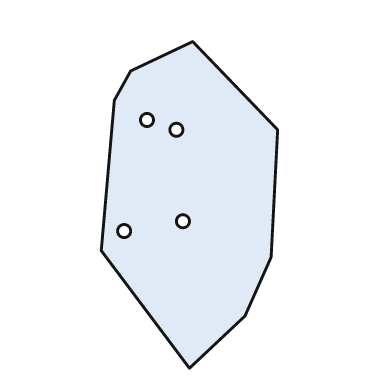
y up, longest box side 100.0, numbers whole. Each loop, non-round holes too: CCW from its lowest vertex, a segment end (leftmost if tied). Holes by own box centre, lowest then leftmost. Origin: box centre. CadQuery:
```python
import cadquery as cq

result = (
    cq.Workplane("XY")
    .moveTo(0.0, -50.0)
    .lineTo(17.0, -34.0)
    .lineTo(25.0, -16.0)
    .lineTo(27.0, 23.0)
    .lineTo(1.0, 50.0)
    .lineTo(-18.0, 41.0)
    .lineTo(-23.0, 32.0)
    .lineTo(-27.0, -14.0)
    .close()
    .moveTo(-20.0, -8.0)
    .circle(2.0)
    .moveTo(-2.0, -5.0)
    .circle(2.0)
    .moveTo(-4.0, 23.0)
    .circle(2.0)
    .moveTo(-13.0, 26.0)
    .circle(2.0)
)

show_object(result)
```